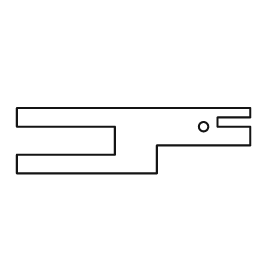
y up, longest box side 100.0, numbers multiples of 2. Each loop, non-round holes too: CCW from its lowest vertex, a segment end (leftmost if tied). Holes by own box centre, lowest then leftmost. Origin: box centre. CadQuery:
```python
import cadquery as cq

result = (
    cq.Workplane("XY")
    .moveTo(-50.0, -14.0)
    .lineTo(10.0, -14.0)
    .lineTo(10.0, -2.0)
    .lineTo(50.0, -2.0)
    .lineTo(50.0, 6.0)
    .lineTo(36.0, 6.0)
    .lineTo(36.0, 10.0)
    .lineTo(50.0, 10.0)
    .lineTo(50.0, 14.0)
    .lineTo(-50.0, 14.0)
    .lineTo(-50.0, 6.0)
    .lineTo(-8.0, 6.0)
    .lineTo(-8.0, -6.0)
    .lineTo(-50.0, -6.0)
    .close()
    .moveTo(30.0, 6.0)
    .circle(2.0)
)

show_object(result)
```